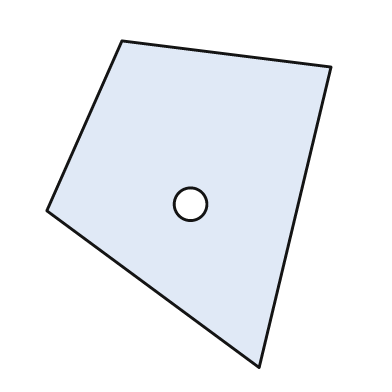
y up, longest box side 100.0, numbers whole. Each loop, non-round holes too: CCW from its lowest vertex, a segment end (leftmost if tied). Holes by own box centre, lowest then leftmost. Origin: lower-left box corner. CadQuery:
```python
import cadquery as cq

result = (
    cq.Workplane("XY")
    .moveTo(65.0, 0.0)
    .lineTo(87.0, 92.0)
    .lineTo(23.0, 100.0)
    .lineTo(0.0, 48.0)
    .close()
    .moveTo(44.0, 50.0)
    .circle(5.0)
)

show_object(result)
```